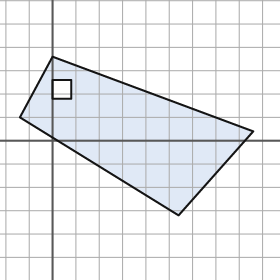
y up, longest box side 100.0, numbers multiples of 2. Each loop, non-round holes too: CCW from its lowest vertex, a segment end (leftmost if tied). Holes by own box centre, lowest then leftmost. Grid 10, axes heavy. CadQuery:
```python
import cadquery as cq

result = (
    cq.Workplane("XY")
    .moveTo(54.0, -32.0)
    .lineTo(86.0, 4.0)
    .lineTo(0.0, 36.0)
    .lineTo(-14.0, 10.0)
    .close()
    .moveTo(0.0, 18.0)
    .lineTo(8.0, 18.0)
    .lineTo(8.0, 26.0)
    .lineTo(0.0, 26.0)
    .close()
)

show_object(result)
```